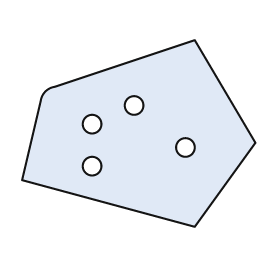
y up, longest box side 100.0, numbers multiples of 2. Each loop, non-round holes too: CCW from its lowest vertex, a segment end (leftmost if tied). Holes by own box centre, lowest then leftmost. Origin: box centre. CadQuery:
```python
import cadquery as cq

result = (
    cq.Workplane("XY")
    .moveTo(24.0, -40.0)
    .lineTo(50.0, -4.0)
    .lineTo(24.0, 40.0)
    .lineTo(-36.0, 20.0)
    .threePointArc((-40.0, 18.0), (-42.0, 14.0))
    .lineTo(-50.0, -20.0)
    .close()
    .moveTo(-20.0, -14.0)
    .circle(4.0)
    .moveTo(20.0, -6.0)
    .circle(4.0)
    .moveTo(-20.0, 4.0)
    .circle(4.0)
    .moveTo(-2.0, 12.0)
    .circle(4.0)
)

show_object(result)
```